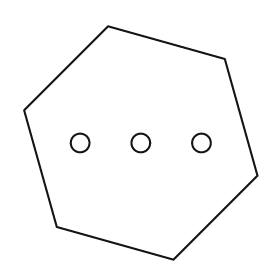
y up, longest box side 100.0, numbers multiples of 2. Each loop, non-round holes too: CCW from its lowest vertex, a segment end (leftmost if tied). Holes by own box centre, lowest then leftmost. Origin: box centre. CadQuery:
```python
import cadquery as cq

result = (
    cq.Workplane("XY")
    .moveTo(14.0, -50.0)
    .lineTo(50.0, -14.0)
    .lineTo(36.0, 36.0)
    .lineTo(-14.0, 50.0)
    .lineTo(-50.0, 14.0)
    .lineTo(-36.0, -36.0)
    .close()
    .moveTo(-26.0, 0.0)
    .circle(4.0)
    .moveTo(0.0, 0.0)
    .circle(4.0)
    .moveTo(26.0, 0.0)
    .circle(4.0)
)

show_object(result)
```